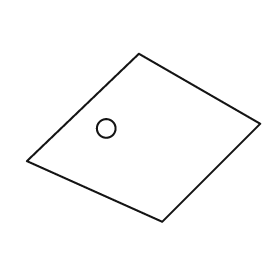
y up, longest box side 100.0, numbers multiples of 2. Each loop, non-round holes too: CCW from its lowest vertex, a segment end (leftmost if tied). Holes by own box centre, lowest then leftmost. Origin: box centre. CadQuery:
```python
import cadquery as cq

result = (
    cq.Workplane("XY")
    .moveTo(8.0, -36.0)
    .lineTo(50.0, 6.0)
    .lineTo(-2.0, 36.0)
    .lineTo(-50.0, -10.0)
    .close()
    .moveTo(-16.0, 4.0)
    .circle(4.0)
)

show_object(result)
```